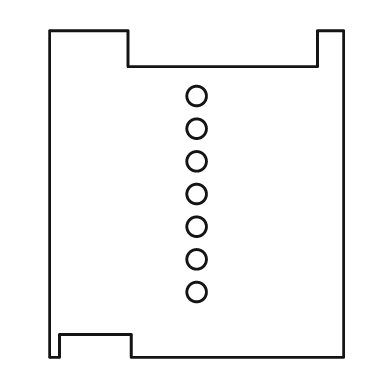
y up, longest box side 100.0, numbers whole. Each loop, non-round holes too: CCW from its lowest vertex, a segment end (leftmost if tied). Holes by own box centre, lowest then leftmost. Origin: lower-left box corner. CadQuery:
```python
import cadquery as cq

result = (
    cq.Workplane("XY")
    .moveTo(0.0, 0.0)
    .lineTo(3.0, 0.0)
    .lineTo(3.0, 7.0)
    .lineTo(25.0, 7.0)
    .lineTo(25.0, 0.0)
    .lineTo(90.0, 0.0)
    .lineTo(90.0, 100.0)
    .lineTo(82.0, 100.0)
    .lineTo(82.0, 89.0)
    .lineTo(24.0, 89.0)
    .lineTo(24.0, 100.0)
    .lineTo(0.0, 100.0)
    .close()
    .moveTo(45.0, 20.0)
    .circle(3.0)
    .moveTo(45.0, 30.0)
    .circle(3.0)
    .moveTo(45.0, 40.0)
    .circle(3.0)
    .moveTo(45.0, 50.0)
    .circle(3.0)
    .moveTo(45.0, 60.0)
    .circle(3.0)
    .moveTo(45.0, 70.0)
    .circle(3.0)
    .moveTo(45.0, 80.0)
    .circle(3.0)
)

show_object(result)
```